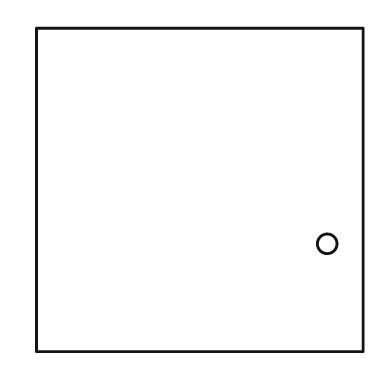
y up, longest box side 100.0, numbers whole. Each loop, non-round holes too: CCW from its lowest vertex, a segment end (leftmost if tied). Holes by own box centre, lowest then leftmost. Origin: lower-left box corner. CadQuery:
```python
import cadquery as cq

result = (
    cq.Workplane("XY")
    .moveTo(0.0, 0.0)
    .lineTo(100.0, 0.0)
    .lineTo(100.0, 99.0)
    .lineTo(0.0, 99.0)
    .close()
    .moveTo(89.0, 33.0)
    .circle(3.0)
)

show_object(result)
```